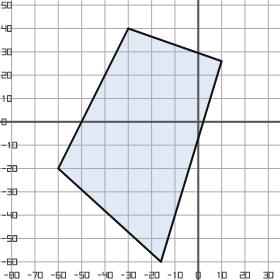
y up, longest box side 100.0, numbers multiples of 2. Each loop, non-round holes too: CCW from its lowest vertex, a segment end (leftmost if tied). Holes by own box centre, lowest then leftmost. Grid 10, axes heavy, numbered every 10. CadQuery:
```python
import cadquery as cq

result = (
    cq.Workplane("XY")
    .moveTo(-16.0, -60.0)
    .lineTo(10.0, 26.0)
    .lineTo(-30.0, 40.0)
    .lineTo(-60.0, -20.0)
    .close()
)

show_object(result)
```